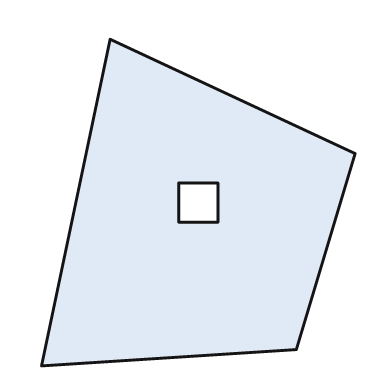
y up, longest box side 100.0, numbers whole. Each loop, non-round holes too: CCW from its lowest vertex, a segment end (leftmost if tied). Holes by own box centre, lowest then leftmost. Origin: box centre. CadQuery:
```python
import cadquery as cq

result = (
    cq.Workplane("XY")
    .moveTo(-48.0, -50.0)
    .lineTo(30.0, -45.0)
    .lineTo(48.0, 15.0)
    .lineTo(-27.0, 50.0)
    .close()
    .moveTo(-6.0, -6.0)
    .lineTo(6.0, -6.0)
    .lineTo(6.0, 6.0)
    .lineTo(-6.0, 6.0)
    .close()
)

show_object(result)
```